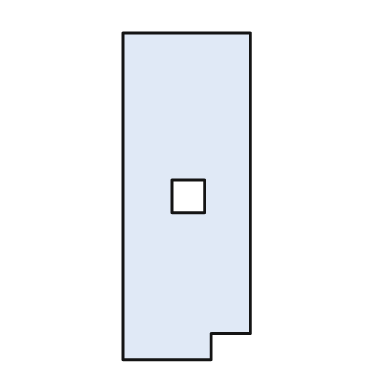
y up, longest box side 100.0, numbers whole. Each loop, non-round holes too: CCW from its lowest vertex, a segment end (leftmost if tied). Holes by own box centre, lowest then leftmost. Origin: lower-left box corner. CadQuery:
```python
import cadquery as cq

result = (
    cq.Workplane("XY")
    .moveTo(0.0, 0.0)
    .lineTo(27.0, 0.0)
    .lineTo(27.0, 8.0)
    .lineTo(39.0, 8.0)
    .lineTo(39.0, 100.0)
    .lineTo(0.0, 100.0)
    .close()
    .moveTo(15.0, 45.0)
    .lineTo(25.0, 45.0)
    .lineTo(25.0, 55.0)
    .lineTo(15.0, 55.0)
    .close()
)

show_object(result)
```